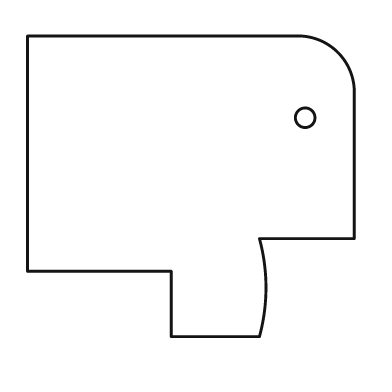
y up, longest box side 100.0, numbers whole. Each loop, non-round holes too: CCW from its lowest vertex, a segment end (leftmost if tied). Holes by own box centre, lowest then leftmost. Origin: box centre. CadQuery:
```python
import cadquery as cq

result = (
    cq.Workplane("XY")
    .moveTo(-6.0, -46.0)
    .lineTo(21.0, -46.0)
    .threePointArc((23.0, -31.0), (21.0, -16.0))
    .lineTo(50.0, -16.0)
    .lineTo(50.0, 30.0)
    .threePointArc((45.0, 41.0), (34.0, 46.0))
    .lineTo(-50.0, 46.0)
    .lineTo(-50.0, -26.0)
    .lineTo(-6.0, -26.0)
    .close()
    .moveTo(35.0, 21.0)
    .circle(3.0)
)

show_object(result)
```